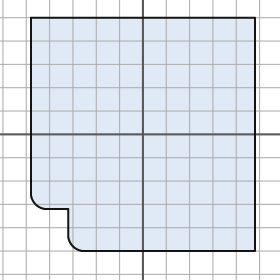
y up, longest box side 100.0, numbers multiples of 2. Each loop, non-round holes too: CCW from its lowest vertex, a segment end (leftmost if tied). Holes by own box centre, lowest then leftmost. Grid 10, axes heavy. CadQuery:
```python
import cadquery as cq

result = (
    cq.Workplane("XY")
    .moveTo(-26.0, -50.0)
    .lineTo(48.0, -50.0)
    .lineTo(48.0, 50.0)
    .lineTo(-48.0, 50.0)
    .lineTo(-48.0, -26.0)
    .threePointArc((-46.0, -30.0), (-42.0, -32.0))
    .lineTo(-32.0, -32.0)
    .lineTo(-32.0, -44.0)
    .threePointArc((-30.0, -48.0), (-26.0, -50.0))
    .close()
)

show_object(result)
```